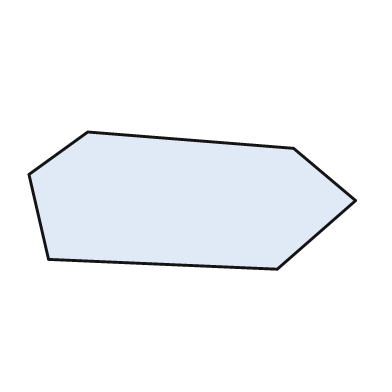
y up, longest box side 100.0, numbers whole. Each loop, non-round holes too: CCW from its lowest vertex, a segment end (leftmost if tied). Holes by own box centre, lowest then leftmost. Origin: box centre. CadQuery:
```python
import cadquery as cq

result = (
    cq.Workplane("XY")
    .moveTo(26.0, -21.0)
    .lineTo(50.0, 0.0)
    .lineTo(31.0, 16.0)
    .lineTo(-32.0, 21.0)
    .lineTo(-50.0, 8.0)
    .lineTo(-44.0, -18.0)
    .close()
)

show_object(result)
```